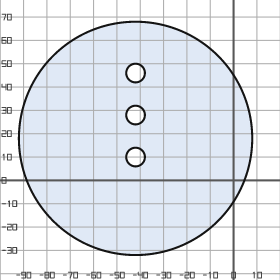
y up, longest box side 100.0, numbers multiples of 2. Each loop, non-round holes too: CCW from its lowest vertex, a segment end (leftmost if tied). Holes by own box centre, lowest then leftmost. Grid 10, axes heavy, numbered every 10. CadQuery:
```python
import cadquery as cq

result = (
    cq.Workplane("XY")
    .moveTo(-42.0, 18.0)
    .circle(50.0)
    .moveTo(-42.0, 10.0)
    .circle(4.0)
    .moveTo(-42.0, 28.0)
    .circle(4.0)
    .moveTo(-42.0, 46.0)
    .circle(4.0)
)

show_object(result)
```